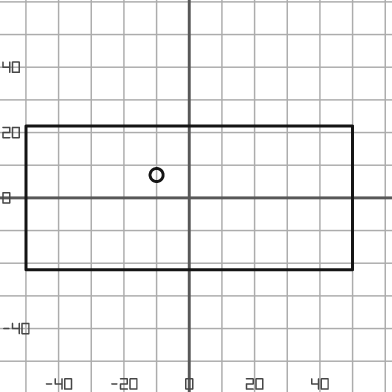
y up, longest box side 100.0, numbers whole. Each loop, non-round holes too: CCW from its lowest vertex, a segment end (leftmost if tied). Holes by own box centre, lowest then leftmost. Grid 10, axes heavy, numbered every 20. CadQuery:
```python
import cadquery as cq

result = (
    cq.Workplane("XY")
    .moveTo(-50.0, -22.0)
    .lineTo(50.0, -22.0)
    .lineTo(50.0, 22.0)
    .lineTo(-50.0, 22.0)
    .close()
    .moveTo(-10.0, 7.0)
    .circle(2.0)
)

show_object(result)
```